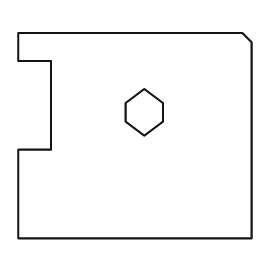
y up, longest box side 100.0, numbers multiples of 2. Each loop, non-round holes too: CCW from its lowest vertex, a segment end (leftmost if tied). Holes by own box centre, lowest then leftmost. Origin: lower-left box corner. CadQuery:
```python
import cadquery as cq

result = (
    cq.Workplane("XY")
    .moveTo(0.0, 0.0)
    .lineTo(100.0, 0.0)
    .lineTo(100.0, 84.0)
    .lineTo(96.0, 88.0)
    .lineTo(0.0, 88.0)
    .lineTo(0.0, 76.0)
    .lineTo(14.0, 76.0)
    .lineTo(14.0, 38.0)
    .lineTo(0.0, 38.0)
    .close()
    .moveTo(54.0, 44.0)
    .lineTo(62.0, 50.0)
    .lineTo(62.0, 58.0)
    .lineTo(54.0, 64.0)
    .lineTo(46.0, 58.0)
    .lineTo(46.0, 50.0)
    .close()
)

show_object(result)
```